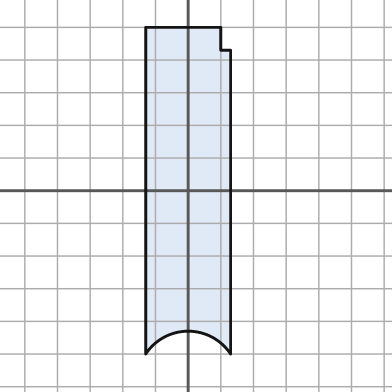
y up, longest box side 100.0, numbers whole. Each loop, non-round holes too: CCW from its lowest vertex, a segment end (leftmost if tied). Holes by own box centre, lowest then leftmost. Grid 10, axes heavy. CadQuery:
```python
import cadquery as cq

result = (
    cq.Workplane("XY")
    .moveTo(-13.0, -50.0)
    .threePointArc((0.0, -43.0), (13.0, -50.0))
    .lineTo(13.0, 43.0)
    .lineTo(10.0, 43.0)
    .lineTo(10.0, 50.0)
    .lineTo(-13.0, 50.0)
    .close()
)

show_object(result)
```